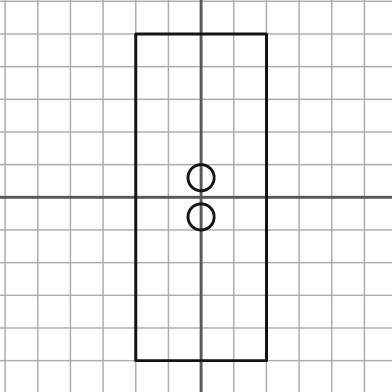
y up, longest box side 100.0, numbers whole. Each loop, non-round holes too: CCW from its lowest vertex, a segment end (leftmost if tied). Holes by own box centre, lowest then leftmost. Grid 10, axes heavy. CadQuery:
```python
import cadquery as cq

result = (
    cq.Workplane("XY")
    .moveTo(-20.0, -50.0)
    .lineTo(20.0, -50.0)
    .lineTo(20.0, 50.0)
    .lineTo(-20.0, 50.0)
    .close()
    .moveTo(0.0, -6.0)
    .circle(4.0)
    .moveTo(0.0, 6.0)
    .circle(4.0)
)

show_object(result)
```